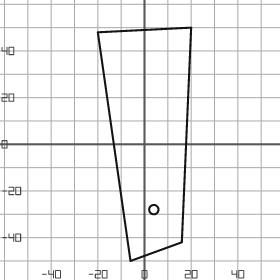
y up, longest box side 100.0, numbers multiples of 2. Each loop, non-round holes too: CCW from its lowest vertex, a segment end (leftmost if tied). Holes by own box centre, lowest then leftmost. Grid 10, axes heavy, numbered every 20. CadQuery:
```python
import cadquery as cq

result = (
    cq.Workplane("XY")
    .moveTo(-6.0, -50.0)
    .lineTo(16.0, -42.0)
    .lineTo(20.0, 50.0)
    .lineTo(-20.0, 48.0)
    .close()
    .moveTo(4.0, -28.0)
    .circle(2.0)
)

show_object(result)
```